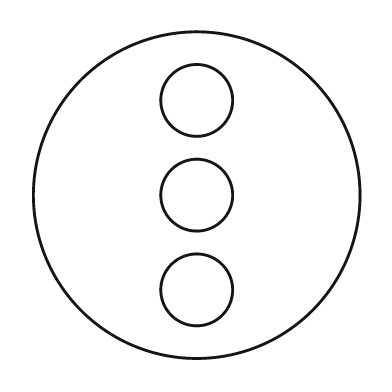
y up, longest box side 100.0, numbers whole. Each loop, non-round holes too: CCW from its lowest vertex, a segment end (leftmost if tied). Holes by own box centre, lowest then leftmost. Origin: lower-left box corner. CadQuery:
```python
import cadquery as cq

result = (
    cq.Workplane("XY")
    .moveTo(50.0, 50.0)
    .circle(50.0)
    .moveTo(50.0, 21.0)
    .circle(11.0)
    .moveTo(50.0, 50.0)
    .circle(11.0)
    .moveTo(50.0, 79.0)
    .circle(11.0)
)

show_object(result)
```